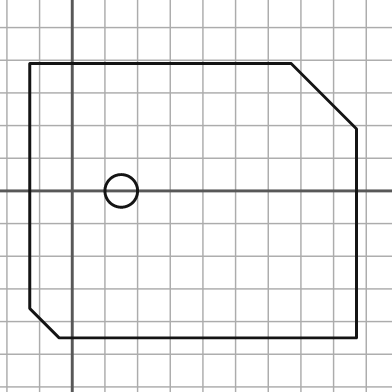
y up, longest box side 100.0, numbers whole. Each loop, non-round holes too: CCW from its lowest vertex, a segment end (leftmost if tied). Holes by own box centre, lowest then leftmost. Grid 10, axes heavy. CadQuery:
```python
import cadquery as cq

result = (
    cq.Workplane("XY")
    .moveTo(-4.0, -45.0)
    .lineTo(87.0, -45.0)
    .lineTo(87.0, 19.0)
    .lineTo(67.0, 39.0)
    .lineTo(-13.0, 39.0)
    .lineTo(-13.0, -36.0)
    .close()
    .moveTo(15.0, 0.0)
    .circle(5.0)
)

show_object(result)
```